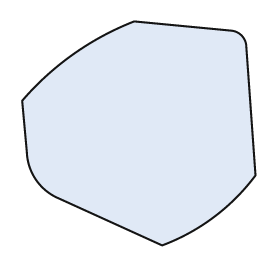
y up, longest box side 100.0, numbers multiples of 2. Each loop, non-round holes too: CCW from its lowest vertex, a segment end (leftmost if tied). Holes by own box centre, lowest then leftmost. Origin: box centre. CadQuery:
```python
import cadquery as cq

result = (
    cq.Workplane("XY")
    .moveTo(10.0, -48.0)
    .threePointArc((32.0, -36.0), (50.0, -18.0))
    .lineTo(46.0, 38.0)
    .threePointArc((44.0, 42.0), (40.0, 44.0))
    .lineTo(-2.0, 48.0)
    .threePointArc((-28.0, 34.0), (-50.0, 14.0))
    .lineTo(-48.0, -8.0)
    .threePointArc((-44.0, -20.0), (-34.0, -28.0))
    .close()
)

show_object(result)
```